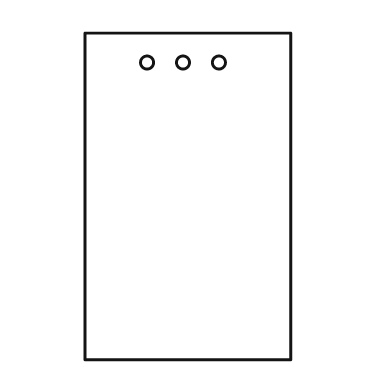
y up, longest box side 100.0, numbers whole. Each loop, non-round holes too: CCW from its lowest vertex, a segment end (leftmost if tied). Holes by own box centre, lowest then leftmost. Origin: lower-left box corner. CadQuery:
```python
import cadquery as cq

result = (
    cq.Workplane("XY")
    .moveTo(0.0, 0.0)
    .lineTo(63.0, 0.0)
    .lineTo(63.0, 100.0)
    .lineTo(0.0, 100.0)
    .close()
    .moveTo(19.0, 91.0)
    .circle(2.0)
    .moveTo(30.0, 91.0)
    .circle(2.0)
    .moveTo(41.0, 91.0)
    .circle(2.0)
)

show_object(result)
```